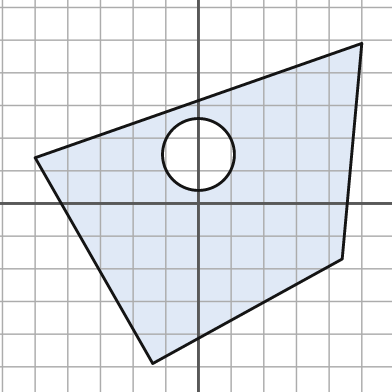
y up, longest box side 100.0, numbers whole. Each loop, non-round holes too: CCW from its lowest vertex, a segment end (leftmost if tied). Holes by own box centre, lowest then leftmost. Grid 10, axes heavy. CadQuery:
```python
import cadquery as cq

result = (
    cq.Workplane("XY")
    .moveTo(-14.0, -49.0)
    .lineTo(44.0, -17.0)
    .lineTo(50.0, 49.0)
    .lineTo(-50.0, 14.0)
    .close()
    .moveTo(0.0, 15.0)
    .circle(11.0)
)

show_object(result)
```